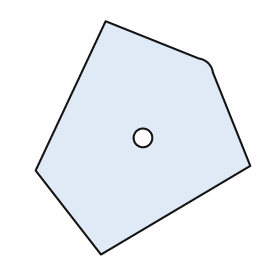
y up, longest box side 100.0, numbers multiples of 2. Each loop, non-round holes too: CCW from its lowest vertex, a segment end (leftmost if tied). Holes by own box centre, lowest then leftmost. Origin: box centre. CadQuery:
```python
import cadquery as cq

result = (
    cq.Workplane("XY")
    .moveTo(-18.0, -50.0)
    .lineTo(46.0, -12.0)
    .lineTo(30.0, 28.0)
    .threePointArc((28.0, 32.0), (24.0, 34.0))
    .lineTo(-16.0, 50.0)
    .lineTo(-46.0, -14.0)
    .close()
    .moveTo(0.0, 0.0)
    .circle(4.0)
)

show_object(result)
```